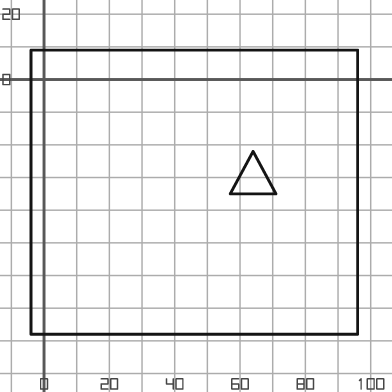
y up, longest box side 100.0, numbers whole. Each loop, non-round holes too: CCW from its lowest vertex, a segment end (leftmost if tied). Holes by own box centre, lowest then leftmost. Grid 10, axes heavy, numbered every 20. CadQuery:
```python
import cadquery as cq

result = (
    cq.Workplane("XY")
    .moveTo(-4.0, -78.0)
    .lineTo(96.0, -78.0)
    .lineTo(96.0, 9.0)
    .lineTo(-4.0, 9.0)
    .close()
    .moveTo(57.0, -35.0)
    .lineTo(71.0, -35.0)
    .lineTo(64.0, -22.0)
    .close()
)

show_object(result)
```